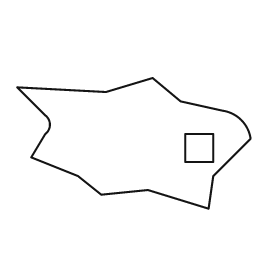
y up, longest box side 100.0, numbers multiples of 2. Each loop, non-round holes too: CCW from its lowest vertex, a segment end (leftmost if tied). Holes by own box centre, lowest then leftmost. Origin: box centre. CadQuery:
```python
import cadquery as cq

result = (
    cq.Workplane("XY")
    .moveTo(32.0, -28.0)
    .lineTo(34.0, -14.0)
    .lineTo(50.0, 2.0)
    .threePointArc((46.0, 10.0), (38.0, 14.0))
    .lineTo(20.0, 18.0)
    .lineTo(8.0, 28.0)
    .lineTo(-12.0, 22.0)
    .lineTo(-50.0, 24.0)
    .lineTo(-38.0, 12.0)
    .threePointArc((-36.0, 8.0), (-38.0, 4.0))
    .lineTo(-44.0, -6.0)
    .lineTo(-24.0, -14.0)
    .lineTo(-14.0, -22.0)
    .lineTo(6.0, -20.0)
    .close()
    .moveTo(22.0, -8.0)
    .lineTo(34.0, -8.0)
    .lineTo(34.0, 4.0)
    .lineTo(22.0, 4.0)
    .close()
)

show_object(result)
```